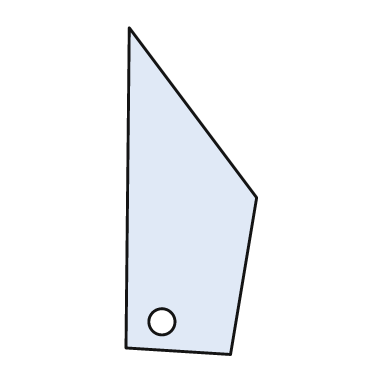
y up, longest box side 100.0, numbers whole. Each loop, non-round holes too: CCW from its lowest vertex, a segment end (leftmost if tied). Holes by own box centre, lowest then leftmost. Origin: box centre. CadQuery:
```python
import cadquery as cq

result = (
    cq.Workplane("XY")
    .moveTo(12.0, -50.0)
    .lineTo(20.0, -2.0)
    .lineTo(-19.0, 50.0)
    .lineTo(-20.0, -48.0)
    .close()
    .moveTo(-9.0, -40.0)
    .circle(4.0)
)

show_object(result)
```